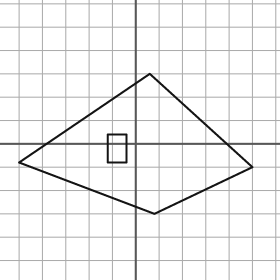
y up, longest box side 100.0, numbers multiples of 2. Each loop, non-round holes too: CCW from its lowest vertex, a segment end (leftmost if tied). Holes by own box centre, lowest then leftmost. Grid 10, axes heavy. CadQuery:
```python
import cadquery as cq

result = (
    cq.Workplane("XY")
    .moveTo(8.0, -30.0)
    .lineTo(50.0, -10.0)
    .lineTo(6.0, 30.0)
    .lineTo(-50.0, -8.0)
    .close()
    .moveTo(-12.0, -8.0)
    .lineTo(-4.0, -8.0)
    .lineTo(-4.0, 4.0)
    .lineTo(-12.0, 4.0)
    .close()
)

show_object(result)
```